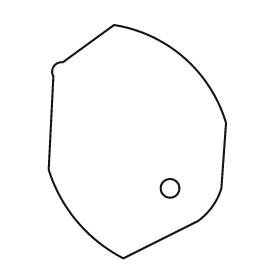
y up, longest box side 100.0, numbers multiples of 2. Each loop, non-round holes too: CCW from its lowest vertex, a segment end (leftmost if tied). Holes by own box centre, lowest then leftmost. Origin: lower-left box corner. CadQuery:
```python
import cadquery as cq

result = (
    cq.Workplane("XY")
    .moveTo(32.0, 0.0)
    .lineTo(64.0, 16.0)
    .threePointArc((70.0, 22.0), (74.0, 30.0))
    .lineTo(76.0, 58.0)
    .threePointArc((58.0, 86.0), (28.0, 100.0))
    .lineTo(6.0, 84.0)
    .threePointArc((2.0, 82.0), (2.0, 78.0))
    .lineTo(0.0, 38.0)
    .threePointArc((12.0, 16.0), (32.0, 0.0))
    .close()
    .moveTo(52.0, 30.0)
    .circle(4.0)
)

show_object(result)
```